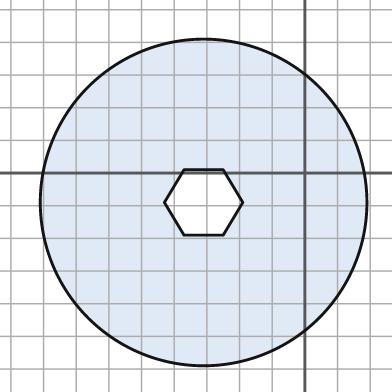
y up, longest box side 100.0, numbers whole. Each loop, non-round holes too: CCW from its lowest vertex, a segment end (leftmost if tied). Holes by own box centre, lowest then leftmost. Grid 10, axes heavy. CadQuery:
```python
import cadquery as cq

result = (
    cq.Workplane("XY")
    .moveTo(-31.0, -9.0)
    .circle(50.0)
    .moveTo(-37.0, -19.0)
    .lineTo(-25.0, -19.0)
    .lineTo(-19.0, -9.0)
    .lineTo(-25.0, 1.0)
    .lineTo(-37.0, 1.0)
    .lineTo(-43.0, -9.0)
    .close()
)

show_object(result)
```